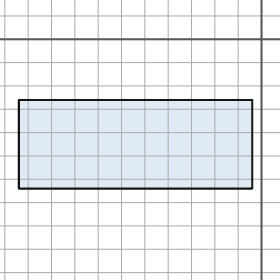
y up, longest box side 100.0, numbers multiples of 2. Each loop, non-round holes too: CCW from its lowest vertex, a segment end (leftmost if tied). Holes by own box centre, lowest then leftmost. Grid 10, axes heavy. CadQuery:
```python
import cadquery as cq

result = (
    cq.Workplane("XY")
    .moveTo(-104.0, -64.0)
    .lineTo(-4.0, -64.0)
    .lineTo(-4.0, -26.0)
    .lineTo(-104.0, -26.0)
    .close()
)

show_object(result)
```